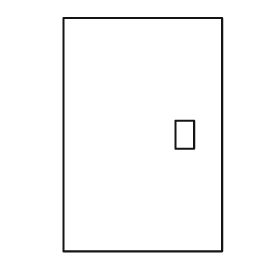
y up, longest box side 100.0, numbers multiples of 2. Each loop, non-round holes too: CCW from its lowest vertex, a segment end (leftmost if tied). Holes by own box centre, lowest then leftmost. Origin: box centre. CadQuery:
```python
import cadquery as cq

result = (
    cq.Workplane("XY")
    .moveTo(-34.0, -50.0)
    .lineTo(34.0, -50.0)
    .lineTo(34.0, 50.0)
    .lineTo(-34.0, 50.0)
    .close()
    .moveTo(14.0, -6.0)
    .lineTo(22.0, -6.0)
    .lineTo(22.0, 6.0)
    .lineTo(14.0, 6.0)
    .close()
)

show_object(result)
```